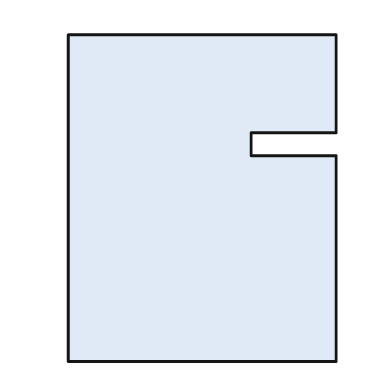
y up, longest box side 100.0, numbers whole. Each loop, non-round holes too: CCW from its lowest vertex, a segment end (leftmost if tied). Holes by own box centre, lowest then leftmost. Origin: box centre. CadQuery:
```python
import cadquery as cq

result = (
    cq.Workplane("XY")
    .moveTo(-41.0, -50.0)
    .lineTo(41.0, -50.0)
    .lineTo(41.0, 13.0)
    .lineTo(15.0, 13.0)
    .lineTo(15.0, 20.0)
    .lineTo(41.0, 20.0)
    .lineTo(41.0, 50.0)
    .lineTo(-41.0, 50.0)
    .close()
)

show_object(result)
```